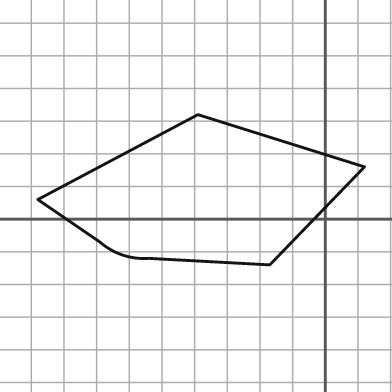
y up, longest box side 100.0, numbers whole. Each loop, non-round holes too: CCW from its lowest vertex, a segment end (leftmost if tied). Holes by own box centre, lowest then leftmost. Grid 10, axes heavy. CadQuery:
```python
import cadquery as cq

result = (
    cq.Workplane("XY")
    .moveTo(-17.0, -14.0)
    .lineTo(12.0, 16.0)
    .lineTo(-39.0, 32.0)
    .lineTo(-88.0, 6.0)
    .lineTo(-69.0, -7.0)
    .threePointArc((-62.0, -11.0), (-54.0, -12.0))
    .close()
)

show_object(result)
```